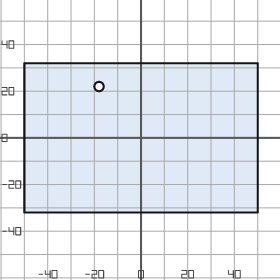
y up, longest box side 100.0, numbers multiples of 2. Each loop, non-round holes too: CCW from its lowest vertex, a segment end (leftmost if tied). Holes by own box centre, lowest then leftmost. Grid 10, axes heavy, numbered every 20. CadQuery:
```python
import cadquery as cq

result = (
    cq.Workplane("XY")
    .moveTo(-50.0, -32.0)
    .lineTo(50.0, -32.0)
    .lineTo(50.0, 32.0)
    .lineTo(-50.0, 32.0)
    .close()
    .moveTo(-18.0, 22.0)
    .circle(2.0)
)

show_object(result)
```